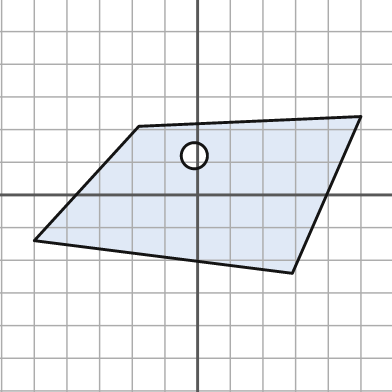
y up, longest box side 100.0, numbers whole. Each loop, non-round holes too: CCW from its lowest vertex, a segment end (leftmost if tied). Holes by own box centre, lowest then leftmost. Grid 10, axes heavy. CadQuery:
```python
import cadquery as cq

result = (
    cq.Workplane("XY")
    .moveTo(29.0, -24.0)
    .lineTo(50.0, 24.0)
    .lineTo(-18.0, 21.0)
    .lineTo(-50.0, -14.0)
    .close()
    .moveTo(-1.0, 12.0)
    .circle(4.0)
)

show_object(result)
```